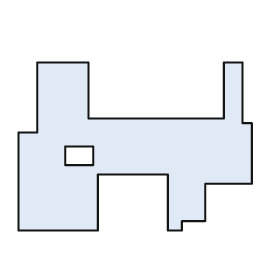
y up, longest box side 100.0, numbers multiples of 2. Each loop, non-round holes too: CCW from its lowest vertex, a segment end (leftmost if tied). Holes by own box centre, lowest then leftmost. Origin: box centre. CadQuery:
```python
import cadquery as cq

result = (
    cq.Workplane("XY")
    .moveTo(-50.0, -36.0)
    .lineTo(-16.0, -36.0)
    .lineTo(-16.0, -12.0)
    .lineTo(14.0, -12.0)
    .lineTo(14.0, -36.0)
    .lineTo(20.0, -36.0)
    .lineTo(20.0, -32.0)
    .lineTo(30.0, -32.0)
    .lineTo(30.0, -16.0)
    .lineTo(50.0, -16.0)
    .lineTo(50.0, 10.0)
    .lineTo(46.0, 10.0)
    .lineTo(46.0, 36.0)
    .lineTo(38.0, 36.0)
    .lineTo(38.0, 12.0)
    .lineTo(-20.0, 12.0)
    .lineTo(-20.0, 36.0)
    .lineTo(-42.0, 36.0)
    .lineTo(-42.0, 6.0)
    .lineTo(-50.0, 6.0)
    .close()
    .moveTo(-30.0, -8.0)
    .lineTo(-18.0, -8.0)
    .lineTo(-18.0, 0.0)
    .lineTo(-30.0, 0.0)
    .close()
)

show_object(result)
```